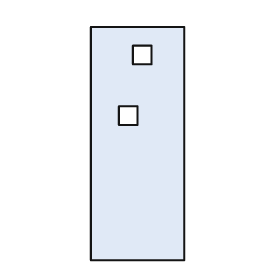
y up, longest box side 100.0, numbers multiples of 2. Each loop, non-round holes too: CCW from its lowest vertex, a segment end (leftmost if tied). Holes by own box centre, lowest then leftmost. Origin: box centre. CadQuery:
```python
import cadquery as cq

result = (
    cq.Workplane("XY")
    .moveTo(-20.0, -50.0)
    .lineTo(20.0, -50.0)
    .lineTo(20.0, 50.0)
    .lineTo(-20.0, 50.0)
    .close()
    .moveTo(-8.0, 8.0)
    .lineTo(0.0, 8.0)
    .lineTo(0.0, 16.0)
    .lineTo(-8.0, 16.0)
    .close()
    .moveTo(-2.0, 34.0)
    .lineTo(6.0, 34.0)
    .lineTo(6.0, 42.0)
    .lineTo(-2.0, 42.0)
    .close()
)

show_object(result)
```